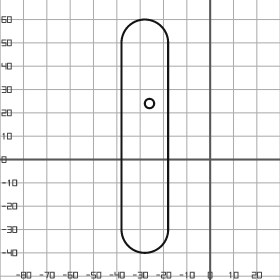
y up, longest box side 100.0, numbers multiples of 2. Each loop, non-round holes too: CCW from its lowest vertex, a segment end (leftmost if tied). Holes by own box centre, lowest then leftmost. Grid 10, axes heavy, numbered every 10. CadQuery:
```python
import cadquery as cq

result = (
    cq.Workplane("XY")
    .moveTo(-38.0, -30.0)
    .threePointArc((-28.0, -40.0), (-18.0, -30.0))
    .lineTo(-18.0, 50.0)
    .threePointArc((-28.0, 60.0), (-38.0, 50.0))
    .close()
    .moveTo(-26.0, 24.0)
    .circle(2.0)
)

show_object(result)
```